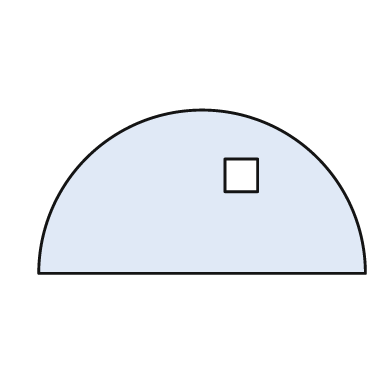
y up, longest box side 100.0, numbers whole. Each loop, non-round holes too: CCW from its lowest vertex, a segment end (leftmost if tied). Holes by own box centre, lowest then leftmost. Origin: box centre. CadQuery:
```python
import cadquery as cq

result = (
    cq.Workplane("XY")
    .moveTo(-50.0, -25.0)
    .lineTo(50.0, -25.0)
    .threePointArc((0.0, 25.0), (-50.0, -25.0))
    .close()
    .moveTo(7.0, 0.0)
    .lineTo(17.0, 0.0)
    .lineTo(17.0, 10.0)
    .lineTo(7.0, 10.0)
    .close()
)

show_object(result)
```